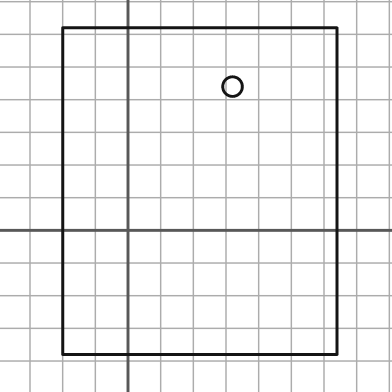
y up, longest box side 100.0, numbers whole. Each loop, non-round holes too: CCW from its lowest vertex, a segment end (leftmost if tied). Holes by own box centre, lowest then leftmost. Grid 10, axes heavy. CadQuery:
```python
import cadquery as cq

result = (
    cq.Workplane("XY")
    .moveTo(-20.0, -38.0)
    .lineTo(64.0, -38.0)
    .lineTo(64.0, 62.0)
    .lineTo(-20.0, 62.0)
    .close()
    .moveTo(32.0, 44.0)
    .circle(3.0)
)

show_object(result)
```